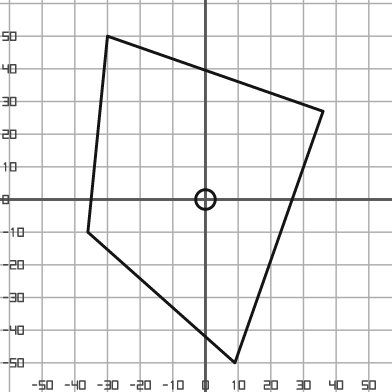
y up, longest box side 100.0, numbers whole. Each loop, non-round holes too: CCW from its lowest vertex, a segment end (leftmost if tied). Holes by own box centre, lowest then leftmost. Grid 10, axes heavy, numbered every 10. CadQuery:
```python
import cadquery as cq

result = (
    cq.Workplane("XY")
    .moveTo(9.0, -50.0)
    .lineTo(36.0, 27.0)
    .lineTo(-30.0, 50.0)
    .lineTo(-36.0, -10.0)
    .close()
    .moveTo(0.0, 0.0)
    .circle(3.0)
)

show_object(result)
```